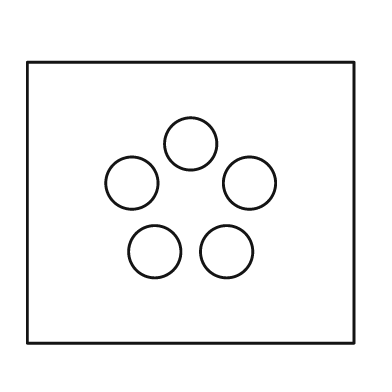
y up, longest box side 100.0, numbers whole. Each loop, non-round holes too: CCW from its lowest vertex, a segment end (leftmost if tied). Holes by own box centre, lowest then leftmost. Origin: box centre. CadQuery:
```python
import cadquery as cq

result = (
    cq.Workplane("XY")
    .moveTo(-50.0, -43.0)
    .lineTo(50.0, -43.0)
    .lineTo(50.0, 43.0)
    .lineTo(-50.0, 43.0)
    .close()
    .moveTo(-11.0, -15.0)
    .circle(8.0)
    .moveTo(11.0, -15.0)
    .circle(8.0)
    .moveTo(-18.0, 6.0)
    .circle(8.0)
    .moveTo(18.0, 6.0)
    .circle(8.0)
    .moveTo(0.0, 18.0)
    .circle(8.0)
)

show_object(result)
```